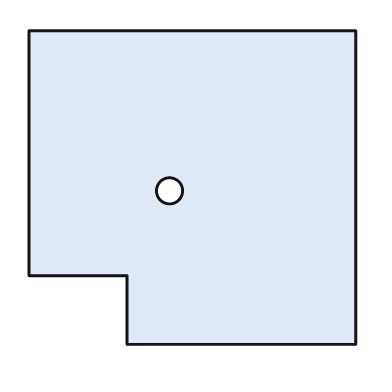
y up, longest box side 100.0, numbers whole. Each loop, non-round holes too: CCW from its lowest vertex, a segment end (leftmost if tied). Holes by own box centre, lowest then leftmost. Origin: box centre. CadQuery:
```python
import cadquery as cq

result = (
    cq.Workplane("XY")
    .moveTo(-20.0, -48.0)
    .lineTo(50.0, -48.0)
    .lineTo(50.0, 48.0)
    .lineTo(-50.0, 48.0)
    .lineTo(-50.0, -27.0)
    .lineTo(-20.0, -27.0)
    .close()
    .moveTo(-7.0, -1.0)
    .circle(4.0)
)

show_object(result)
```